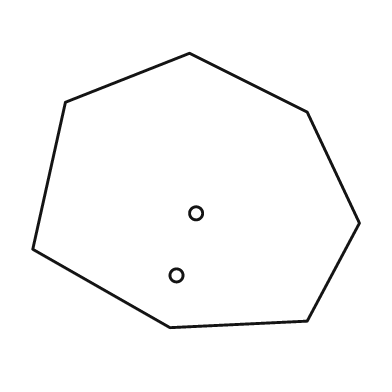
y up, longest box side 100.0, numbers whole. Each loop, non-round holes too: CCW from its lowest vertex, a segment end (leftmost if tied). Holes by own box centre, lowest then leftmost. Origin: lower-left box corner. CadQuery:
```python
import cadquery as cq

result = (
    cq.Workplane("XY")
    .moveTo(42.0, 0.0)
    .lineTo(84.0, 2.0)
    .lineTo(100.0, 32.0)
    .lineTo(84.0, 66.0)
    .lineTo(48.0, 84.0)
    .lineTo(10.0, 69.0)
    .lineTo(0.0, 24.0)
    .close()
    .moveTo(44.0, 16.0)
    .circle(2.0)
    .moveTo(50.0, 35.0)
    .circle(2.0)
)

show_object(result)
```